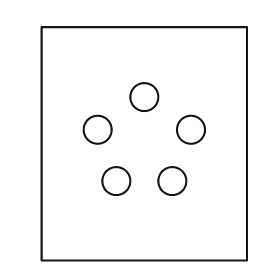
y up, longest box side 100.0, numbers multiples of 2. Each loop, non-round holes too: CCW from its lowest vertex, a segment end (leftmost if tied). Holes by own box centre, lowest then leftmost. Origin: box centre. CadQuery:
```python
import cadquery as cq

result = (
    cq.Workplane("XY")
    .moveTo(-44.0, -50.0)
    .lineTo(44.0, -50.0)
    .lineTo(44.0, 50.0)
    .lineTo(-44.0, 50.0)
    .close()
    .moveTo(-12.0, -16.0)
    .circle(6.0)
    .moveTo(12.0, -16.0)
    .circle(6.0)
    .moveTo(-20.0, 6.0)
    .circle(6.0)
    .moveTo(20.0, 6.0)
    .circle(6.0)
    .moveTo(0.0, 20.0)
    .circle(6.0)
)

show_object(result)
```